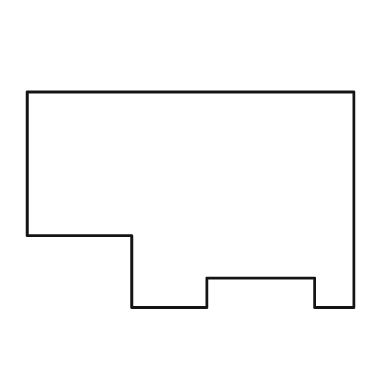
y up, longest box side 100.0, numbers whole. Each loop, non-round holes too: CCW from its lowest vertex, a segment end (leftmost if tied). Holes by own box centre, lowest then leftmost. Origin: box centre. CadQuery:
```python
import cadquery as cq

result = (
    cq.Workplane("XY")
    .moveTo(-18.0, -33.0)
    .lineTo(5.0, -33.0)
    .lineTo(5.0, -24.0)
    .lineTo(38.0, -24.0)
    .lineTo(38.0, -33.0)
    .lineTo(50.0, -33.0)
    .lineTo(50.0, 33.0)
    .lineTo(-50.0, 33.0)
    .lineTo(-50.0, -11.0)
    .lineTo(-18.0, -11.0)
    .close()
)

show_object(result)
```